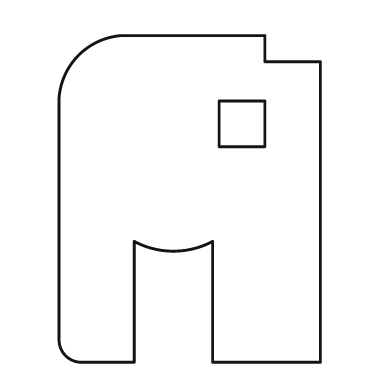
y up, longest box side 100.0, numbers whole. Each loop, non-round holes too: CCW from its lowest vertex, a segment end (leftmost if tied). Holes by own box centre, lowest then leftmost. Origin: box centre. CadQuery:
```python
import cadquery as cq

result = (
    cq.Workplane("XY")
    .moveTo(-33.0, -50.0)
    .lineTo(-17.0, -50.0)
    .lineTo(-17.0, -13.0)
    .threePointArc((-5.0, -16.0), (7.0, -13.0))
    .lineTo(7.0, -50.0)
    .lineTo(40.0, -50.0)
    .lineTo(40.0, 42.0)
    .lineTo(23.0, 42.0)
    .lineTo(23.0, 50.0)
    .lineTo(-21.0, 50.0)
    .threePointArc((-34.0, 44.0), (-40.0, 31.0))
    .lineTo(-40.0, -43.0)
    .threePointArc((-38.0, -48.0), (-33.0, -50.0))
    .close()
    .moveTo(9.0, 16.0)
    .lineTo(23.0, 16.0)
    .lineTo(23.0, 30.0)
    .lineTo(9.0, 30.0)
    .close()
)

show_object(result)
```